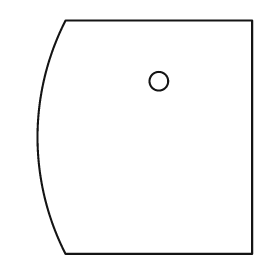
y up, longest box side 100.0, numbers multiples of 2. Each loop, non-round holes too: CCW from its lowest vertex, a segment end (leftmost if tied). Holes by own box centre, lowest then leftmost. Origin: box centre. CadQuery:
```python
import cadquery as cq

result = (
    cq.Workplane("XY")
    .moveTo(-34.0, -50.0)
    .lineTo(46.0, -50.0)
    .lineTo(46.0, 50.0)
    .lineTo(-34.0, 50.0)
    .threePointArc((-46.0, 0.0), (-34.0, -50.0))
    .close()
    .moveTo(6.0, 24.0)
    .circle(4.0)
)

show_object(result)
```